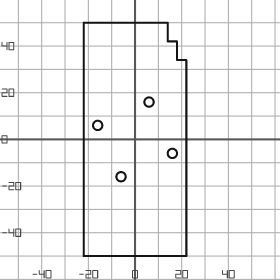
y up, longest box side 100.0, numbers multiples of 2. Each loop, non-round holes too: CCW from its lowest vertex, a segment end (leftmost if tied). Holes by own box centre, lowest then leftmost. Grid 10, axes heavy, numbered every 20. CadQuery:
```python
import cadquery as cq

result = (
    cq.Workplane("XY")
    .moveTo(-22.0, -50.0)
    .lineTo(22.0, -50.0)
    .lineTo(22.0, 34.0)
    .lineTo(18.0, 34.0)
    .lineTo(18.0, 42.0)
    .lineTo(14.0, 42.0)
    .lineTo(14.0, 50.0)
    .lineTo(-22.0, 50.0)
    .close()
    .moveTo(-6.0, -16.0)
    .circle(2.0)
    .moveTo(16.0, -6.0)
    .circle(2.0)
    .moveTo(-16.0, 6.0)
    .circle(2.0)
    .moveTo(6.0, 16.0)
    .circle(2.0)
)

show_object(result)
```